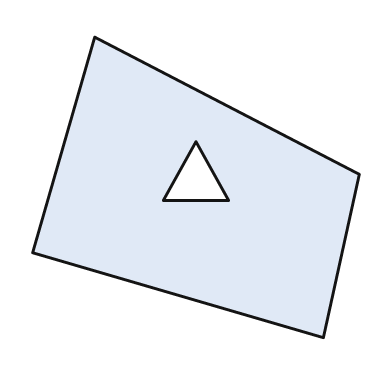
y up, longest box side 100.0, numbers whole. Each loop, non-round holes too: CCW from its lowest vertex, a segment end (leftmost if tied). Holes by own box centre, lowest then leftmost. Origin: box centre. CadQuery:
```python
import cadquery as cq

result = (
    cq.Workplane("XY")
    .moveTo(39.0, -46.0)
    .lineTo(50.0, 4.0)
    .lineTo(-31.0, 46.0)
    .lineTo(-50.0, -20.0)
    .close()
    .moveTo(-10.0, -4.0)
    .lineTo(10.0, -4.0)
    .lineTo(0.0, 14.0)
    .close()
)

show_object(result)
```